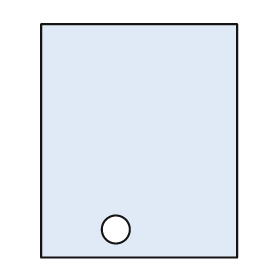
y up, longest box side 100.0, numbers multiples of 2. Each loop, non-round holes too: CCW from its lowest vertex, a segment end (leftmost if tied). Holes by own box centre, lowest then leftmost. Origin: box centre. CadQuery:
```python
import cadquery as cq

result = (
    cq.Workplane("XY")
    .moveTo(-42.0, -50.0)
    .lineTo(42.0, -50.0)
    .lineTo(42.0, 50.0)
    .lineTo(-42.0, 50.0)
    .close()
    .moveTo(-10.0, -38.0)
    .circle(6.0)
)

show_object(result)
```